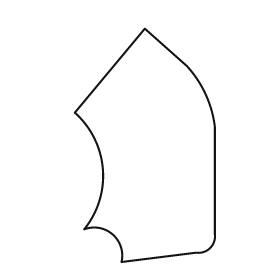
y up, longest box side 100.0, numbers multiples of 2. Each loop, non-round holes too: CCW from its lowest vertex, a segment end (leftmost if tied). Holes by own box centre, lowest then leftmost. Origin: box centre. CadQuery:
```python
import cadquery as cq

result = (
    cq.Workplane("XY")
    .moveTo(-10.0, -50.0)
    .lineTo(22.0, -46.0)
    .threePointArc((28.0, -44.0), (30.0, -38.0))
    .lineTo(30.0, 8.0)
    .threePointArc((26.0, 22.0), (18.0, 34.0))
    .lineTo(0.0, 50.0)
    .lineTo(-30.0, 14.0)
    .threePointArc((-18.0, -10.0), (-26.0, -36.0))
    .threePointArc((-14.0, -38.0), (-10.0, -50.0))
    .close()
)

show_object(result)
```